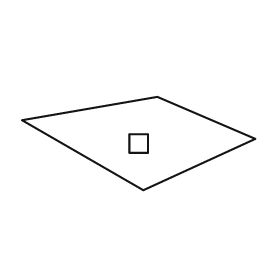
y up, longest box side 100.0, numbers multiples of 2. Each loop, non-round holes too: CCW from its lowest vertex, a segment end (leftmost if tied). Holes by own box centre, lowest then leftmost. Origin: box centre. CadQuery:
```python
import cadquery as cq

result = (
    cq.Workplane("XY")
    .moveTo(2.0, -20.0)
    .lineTo(50.0, 2.0)
    .lineTo(8.0, 20.0)
    .lineTo(-50.0, 10.0)
    .close()
    .moveTo(-4.0, -4.0)
    .lineTo(4.0, -4.0)
    .lineTo(4.0, 4.0)
    .lineTo(-4.0, 4.0)
    .close()
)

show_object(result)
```